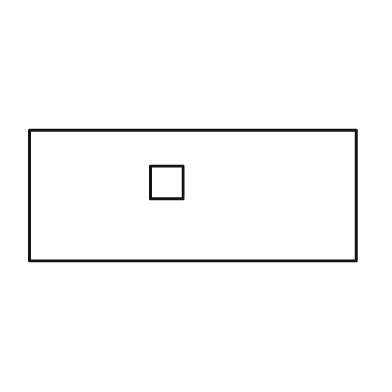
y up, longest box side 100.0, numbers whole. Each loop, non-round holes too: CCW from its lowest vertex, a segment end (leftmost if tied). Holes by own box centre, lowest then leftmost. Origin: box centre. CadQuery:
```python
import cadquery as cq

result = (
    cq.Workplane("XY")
    .moveTo(-50.0, -20.0)
    .lineTo(50.0, -20.0)
    .lineTo(50.0, 20.0)
    .lineTo(-50.0, 20.0)
    .close()
    .moveTo(-13.0, -1.0)
    .lineTo(-3.0, -1.0)
    .lineTo(-3.0, 9.0)
    .lineTo(-13.0, 9.0)
    .close()
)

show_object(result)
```